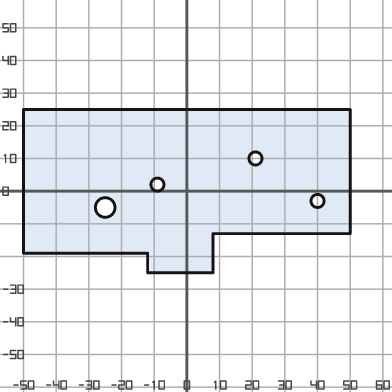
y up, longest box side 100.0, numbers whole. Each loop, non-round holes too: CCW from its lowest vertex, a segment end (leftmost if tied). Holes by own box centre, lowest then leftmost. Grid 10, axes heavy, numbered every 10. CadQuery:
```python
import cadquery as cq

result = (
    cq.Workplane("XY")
    .moveTo(-12.0, -25.0)
    .lineTo(8.0, -25.0)
    .lineTo(8.0, -13.0)
    .lineTo(50.0, -13.0)
    .lineTo(50.0, 25.0)
    .lineTo(-50.0, 25.0)
    .lineTo(-50.0, -19.0)
    .lineTo(-12.0, -19.0)
    .close()
    .moveTo(-25.0, -5.0)
    .circle(3.0)
    .moveTo(40.0, -3.0)
    .circle(2.0)
    .moveTo(-9.0, 2.0)
    .circle(2.0)
    .moveTo(21.0, 10.0)
    .circle(2.0)
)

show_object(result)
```